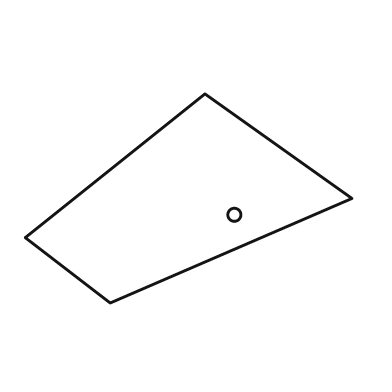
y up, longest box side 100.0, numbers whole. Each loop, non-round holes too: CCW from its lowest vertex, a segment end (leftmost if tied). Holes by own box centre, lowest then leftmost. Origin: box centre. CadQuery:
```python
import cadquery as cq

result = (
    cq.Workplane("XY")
    .moveTo(-24.0, -32.0)
    .lineTo(50.0, 0.0)
    .lineTo(5.0, 32.0)
    .lineTo(-50.0, -12.0)
    .close()
    .moveTo(14.0, -5.0)
    .circle(2.0)
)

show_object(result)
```